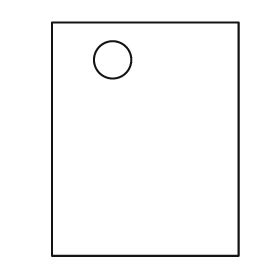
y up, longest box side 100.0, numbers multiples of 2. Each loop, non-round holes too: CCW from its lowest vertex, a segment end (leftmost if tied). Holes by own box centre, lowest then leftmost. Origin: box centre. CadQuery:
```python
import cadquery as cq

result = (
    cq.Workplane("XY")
    .moveTo(-40.0, -50.0)
    .lineTo(40.0, -50.0)
    .lineTo(40.0, 50.0)
    .lineTo(-40.0, 50.0)
    .close()
    .moveTo(-14.0, 34.0)
    .circle(8.0)
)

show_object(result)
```